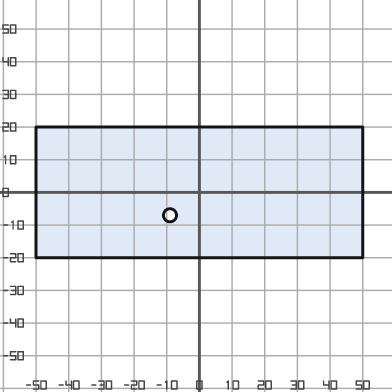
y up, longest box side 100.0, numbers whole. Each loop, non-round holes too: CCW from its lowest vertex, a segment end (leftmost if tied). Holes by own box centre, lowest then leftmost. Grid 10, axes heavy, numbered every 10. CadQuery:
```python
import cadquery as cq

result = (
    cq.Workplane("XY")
    .moveTo(-50.0, -20.0)
    .lineTo(50.0, -20.0)
    .lineTo(50.0, 20.0)
    .lineTo(-50.0, 20.0)
    .close()
    .moveTo(-9.0, -7.0)
    .circle(2.0)
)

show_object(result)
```